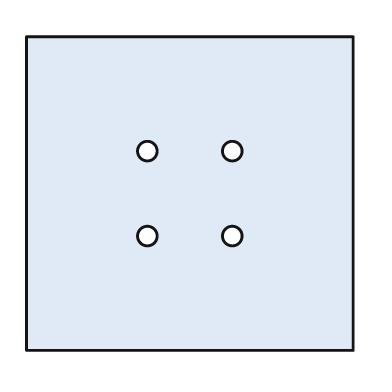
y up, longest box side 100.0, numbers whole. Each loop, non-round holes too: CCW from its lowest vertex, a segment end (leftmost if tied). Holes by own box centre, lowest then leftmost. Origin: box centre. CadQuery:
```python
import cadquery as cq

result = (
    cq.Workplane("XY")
    .moveTo(-50.0, -48.0)
    .lineTo(50.0, -48.0)
    .lineTo(50.0, 48.0)
    .lineTo(-50.0, 48.0)
    .close()
    .moveTo(-13.0, -13.0)
    .circle(3.0)
    .moveTo(13.0, -13.0)
    .circle(3.0)
    .moveTo(-13.0, 13.0)
    .circle(3.0)
    .moveTo(13.0, 13.0)
    .circle(3.0)
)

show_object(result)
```